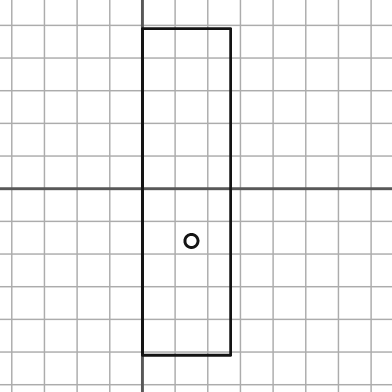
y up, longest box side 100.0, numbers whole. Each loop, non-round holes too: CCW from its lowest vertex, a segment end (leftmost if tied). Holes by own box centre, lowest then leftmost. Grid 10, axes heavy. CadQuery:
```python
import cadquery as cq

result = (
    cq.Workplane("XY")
    .moveTo(0.0, -51.0)
    .lineTo(27.0, -51.0)
    .lineTo(27.0, 49.0)
    .lineTo(0.0, 49.0)
    .close()
    .moveTo(15.0, -16.0)
    .circle(2.0)
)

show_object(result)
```